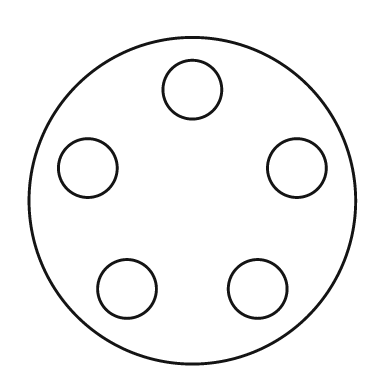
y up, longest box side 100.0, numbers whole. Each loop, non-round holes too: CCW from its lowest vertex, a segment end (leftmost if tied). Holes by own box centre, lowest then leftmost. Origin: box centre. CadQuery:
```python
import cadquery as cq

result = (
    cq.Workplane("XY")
    .moveTo(0.0, 0.0)
    .circle(50.0)
    .moveTo(-20.0, -27.0)
    .circle(9.0)
    .moveTo(20.0, -27.0)
    .circle(9.0)
    .moveTo(-32.0, 10.0)
    .circle(9.0)
    .moveTo(32.0, 10.0)
    .circle(9.0)
    .moveTo(0.0, 34.0)
    .circle(9.0)
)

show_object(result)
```